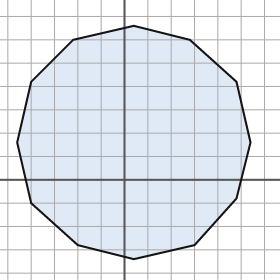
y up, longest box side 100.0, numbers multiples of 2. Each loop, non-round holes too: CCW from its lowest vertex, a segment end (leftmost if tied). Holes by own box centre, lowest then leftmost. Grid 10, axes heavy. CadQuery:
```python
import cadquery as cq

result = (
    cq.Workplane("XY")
    .moveTo(4.0, -34.0)
    .lineTo(30.0, -28.0)
    .lineTo(48.0, -8.0)
    .lineTo(54.0, 16.0)
    .lineTo(48.0, 42.0)
    .lineTo(28.0, 60.0)
    .lineTo(4.0, 66.0)
    .lineTo(-22.0, 60.0)
    .lineTo(-40.0, 42.0)
    .lineTo(-46.0, 16.0)
    .lineTo(-40.0, -10.0)
    .lineTo(-20.0, -28.0)
    .close()
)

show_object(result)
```